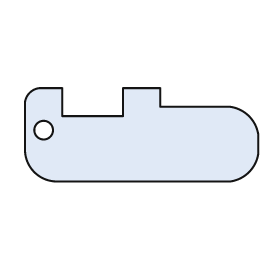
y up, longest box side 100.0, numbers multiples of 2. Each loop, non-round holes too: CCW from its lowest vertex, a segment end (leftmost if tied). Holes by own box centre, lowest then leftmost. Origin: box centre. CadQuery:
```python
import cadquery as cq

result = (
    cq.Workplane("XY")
    .moveTo(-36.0, -20.0)
    .lineTo(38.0, -20.0)
    .threePointArc((46.0, -16.0), (50.0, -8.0))
    .lineTo(50.0, 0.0)
    .threePointArc((46.0, 8.0), (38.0, 12.0))
    .lineTo(8.0, 12.0)
    .lineTo(8.0, 20.0)
    .lineTo(-8.0, 20.0)
    .lineTo(-8.0, 8.0)
    .lineTo(-34.0, 8.0)
    .lineTo(-34.0, 20.0)
    .lineTo(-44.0, 20.0)
    .threePointArc((-48.0, 18.0), (-50.0, 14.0))
    .lineTo(-50.0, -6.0)
    .threePointArc((-46.0, -16.0), (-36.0, -20.0))
    .close()
    .moveTo(-42.0, 2.0)
    .circle(4.0)
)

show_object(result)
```